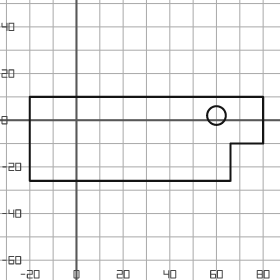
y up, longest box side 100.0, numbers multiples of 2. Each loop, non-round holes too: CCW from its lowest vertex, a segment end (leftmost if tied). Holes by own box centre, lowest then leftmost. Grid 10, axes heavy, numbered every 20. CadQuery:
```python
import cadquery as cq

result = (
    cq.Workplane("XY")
    .moveTo(-20.0, -26.0)
    .lineTo(66.0, -26.0)
    .lineTo(66.0, -10.0)
    .lineTo(80.0, -10.0)
    .lineTo(80.0, 10.0)
    .lineTo(-20.0, 10.0)
    .close()
    .moveTo(60.0, 2.0)
    .circle(4.0)
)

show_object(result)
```